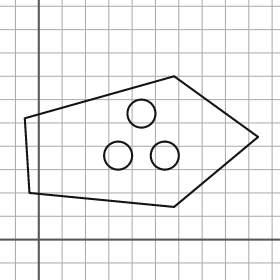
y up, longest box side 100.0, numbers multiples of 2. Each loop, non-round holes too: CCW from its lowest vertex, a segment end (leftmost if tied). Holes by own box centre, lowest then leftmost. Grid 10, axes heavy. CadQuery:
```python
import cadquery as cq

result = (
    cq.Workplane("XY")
    .moveTo(58.0, 14.0)
    .lineTo(94.0, 44.0)
    .lineTo(58.0, 70.0)
    .lineTo(-6.0, 52.0)
    .lineTo(-4.0, 20.0)
    .close()
    .moveTo(34.0, 36.0)
    .circle(6.0)
    .moveTo(54.0, 36.0)
    .circle(6.0)
    .moveTo(44.0, 54.0)
    .circle(6.0)
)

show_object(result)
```